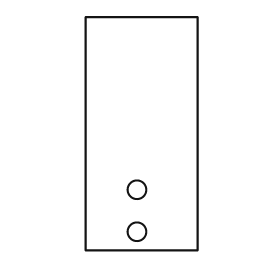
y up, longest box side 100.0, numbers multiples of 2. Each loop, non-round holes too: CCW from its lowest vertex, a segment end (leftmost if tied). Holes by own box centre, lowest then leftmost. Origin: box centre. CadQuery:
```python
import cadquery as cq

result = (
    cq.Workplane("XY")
    .moveTo(-24.0, -50.0)
    .lineTo(24.0, -50.0)
    .lineTo(24.0, 50.0)
    .lineTo(-24.0, 50.0)
    .close()
    .moveTo(-2.0, -42.0)
    .circle(4.0)
    .moveTo(-2.0, -24.0)
    .circle(4.0)
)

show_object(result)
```